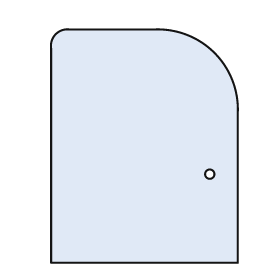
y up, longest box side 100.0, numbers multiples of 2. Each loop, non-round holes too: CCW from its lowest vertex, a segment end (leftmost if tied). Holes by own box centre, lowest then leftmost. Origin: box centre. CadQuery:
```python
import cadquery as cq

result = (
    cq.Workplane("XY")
    .moveTo(-40.0, -50.0)
    .lineTo(40.0, -50.0)
    .lineTo(40.0, 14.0)
    .threePointArc((30.0, 40.0), (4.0, 50.0))
    .lineTo(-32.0, 50.0)
    .threePointArc((-38.0, 48.0), (-40.0, 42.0))
    .close()
    .moveTo(28.0, -12.0)
    .circle(2.0)
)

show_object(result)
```